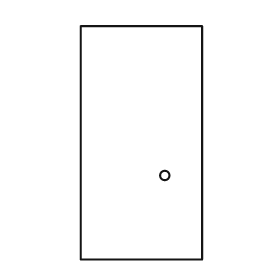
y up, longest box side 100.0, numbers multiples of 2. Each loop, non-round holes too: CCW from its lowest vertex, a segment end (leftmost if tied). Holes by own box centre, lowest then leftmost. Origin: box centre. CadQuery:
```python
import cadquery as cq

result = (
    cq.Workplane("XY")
    .moveTo(-26.0, -50.0)
    .lineTo(26.0, -50.0)
    .lineTo(26.0, 50.0)
    .lineTo(-26.0, 50.0)
    .close()
    .moveTo(10.0, -14.0)
    .circle(2.0)
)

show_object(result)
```